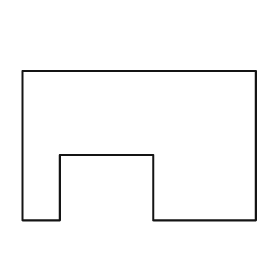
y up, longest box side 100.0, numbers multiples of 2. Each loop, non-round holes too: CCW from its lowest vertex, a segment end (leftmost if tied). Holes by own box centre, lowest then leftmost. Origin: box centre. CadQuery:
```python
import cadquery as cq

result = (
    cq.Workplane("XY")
    .moveTo(-50.0, -32.0)
    .lineTo(-34.0, -32.0)
    .lineTo(-34.0, -4.0)
    .lineTo(6.0, -4.0)
    .lineTo(6.0, -32.0)
    .lineTo(50.0, -32.0)
    .lineTo(50.0, 32.0)
    .lineTo(-50.0, 32.0)
    .close()
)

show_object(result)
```